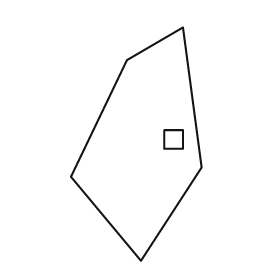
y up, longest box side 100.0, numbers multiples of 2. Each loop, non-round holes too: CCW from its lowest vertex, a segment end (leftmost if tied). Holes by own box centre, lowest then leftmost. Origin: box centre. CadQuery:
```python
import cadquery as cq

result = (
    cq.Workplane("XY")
    .moveTo(2.0, -50.0)
    .lineTo(28.0, -10.0)
    .lineTo(20.0, 50.0)
    .lineTo(-4.0, 36.0)
    .lineTo(-28.0, -14.0)
    .close()
    .moveTo(12.0, -2.0)
    .lineTo(20.0, -2.0)
    .lineTo(20.0, 6.0)
    .lineTo(12.0, 6.0)
    .close()
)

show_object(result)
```